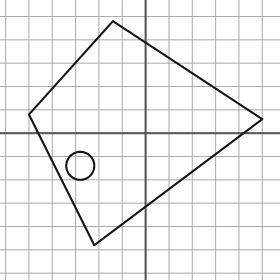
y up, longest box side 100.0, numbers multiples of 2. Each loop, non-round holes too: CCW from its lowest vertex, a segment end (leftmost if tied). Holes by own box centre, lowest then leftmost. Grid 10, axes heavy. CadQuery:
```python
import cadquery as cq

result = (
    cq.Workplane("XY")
    .moveTo(-22.0, -48.0)
    .lineTo(50.0, 6.0)
    .lineTo(-14.0, 48.0)
    .lineTo(-50.0, 8.0)
    .close()
    .moveTo(-28.0, -14.0)
    .circle(6.0)
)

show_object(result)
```